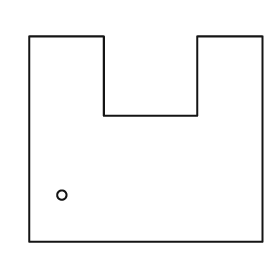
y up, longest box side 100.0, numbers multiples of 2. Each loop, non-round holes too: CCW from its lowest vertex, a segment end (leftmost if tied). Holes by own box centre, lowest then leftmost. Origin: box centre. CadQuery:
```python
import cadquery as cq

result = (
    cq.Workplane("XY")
    .moveTo(-50.0, -44.0)
    .lineTo(50.0, -44.0)
    .lineTo(50.0, 44.0)
    .lineTo(22.0, 44.0)
    .lineTo(22.0, 10.0)
    .lineTo(-18.0, 10.0)
    .lineTo(-18.0, 44.0)
    .lineTo(-50.0, 44.0)
    .close()
    .moveTo(-36.0, -24.0)
    .circle(2.0)
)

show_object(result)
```